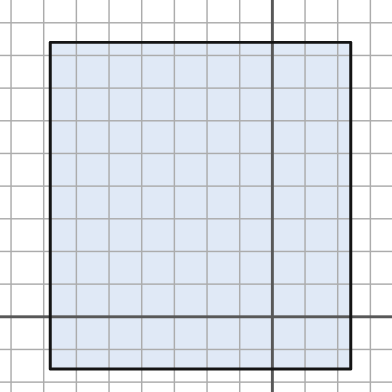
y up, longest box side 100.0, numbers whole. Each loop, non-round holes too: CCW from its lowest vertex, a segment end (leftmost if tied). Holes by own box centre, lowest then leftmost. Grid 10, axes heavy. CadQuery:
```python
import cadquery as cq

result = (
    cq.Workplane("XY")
    .moveTo(-68.0, -16.0)
    .lineTo(24.0, -16.0)
    .lineTo(24.0, 84.0)
    .lineTo(-68.0, 84.0)
    .close()
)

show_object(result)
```